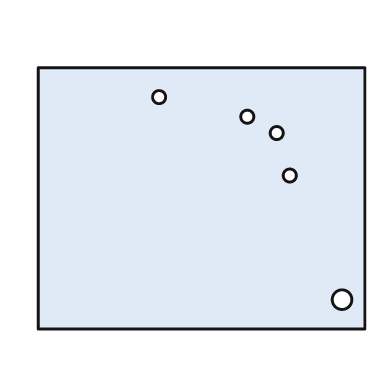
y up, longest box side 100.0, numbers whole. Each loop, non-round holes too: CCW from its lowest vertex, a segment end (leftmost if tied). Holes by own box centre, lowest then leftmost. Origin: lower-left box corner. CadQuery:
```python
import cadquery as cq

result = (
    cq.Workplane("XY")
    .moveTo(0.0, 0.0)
    .lineTo(100.0, 0.0)
    .lineTo(100.0, 80.0)
    .lineTo(0.0, 80.0)
    .close()
    .moveTo(93.0, 9.0)
    .circle(3.0)
    .moveTo(77.0, 47.0)
    .circle(2.0)
    .moveTo(73.0, 60.0)
    .circle(2.0)
    .moveTo(64.0, 65.0)
    .circle(2.0)
    .moveTo(37.0, 71.0)
    .circle(2.0)
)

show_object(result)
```